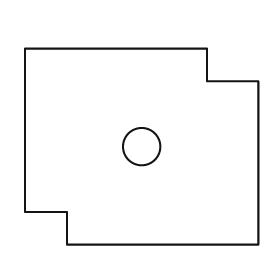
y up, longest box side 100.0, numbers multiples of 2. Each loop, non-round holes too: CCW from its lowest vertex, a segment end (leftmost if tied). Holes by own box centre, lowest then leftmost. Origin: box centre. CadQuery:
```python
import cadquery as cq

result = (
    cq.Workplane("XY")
    .moveTo(-32.0, -42.0)
    .lineTo(50.0, -42.0)
    .lineTo(50.0, 28.0)
    .lineTo(28.0, 28.0)
    .lineTo(28.0, 42.0)
    .lineTo(-50.0, 42.0)
    .lineTo(-50.0, -28.0)
    .lineTo(-32.0, -28.0)
    .close()
    .moveTo(0.0, 0.0)
    .circle(8.0)
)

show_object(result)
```